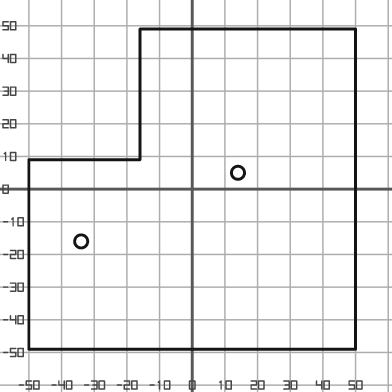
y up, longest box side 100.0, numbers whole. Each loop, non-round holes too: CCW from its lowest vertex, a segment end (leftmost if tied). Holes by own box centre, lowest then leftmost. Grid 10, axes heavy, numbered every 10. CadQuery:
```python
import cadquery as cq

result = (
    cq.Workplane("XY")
    .moveTo(-50.0, -49.0)
    .lineTo(50.0, -49.0)
    .lineTo(50.0, 49.0)
    .lineTo(-16.0, 49.0)
    .lineTo(-16.0, 9.0)
    .lineTo(-50.0, 9.0)
    .close()
    .moveTo(-34.0, -16.0)
    .circle(2.0)
    .moveTo(14.0, 5.0)
    .circle(2.0)
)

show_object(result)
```